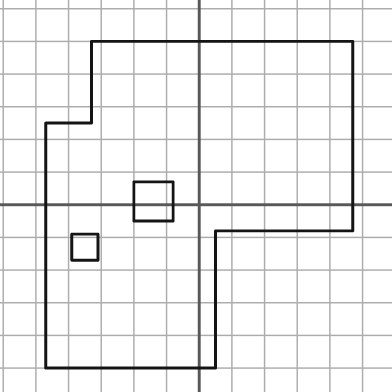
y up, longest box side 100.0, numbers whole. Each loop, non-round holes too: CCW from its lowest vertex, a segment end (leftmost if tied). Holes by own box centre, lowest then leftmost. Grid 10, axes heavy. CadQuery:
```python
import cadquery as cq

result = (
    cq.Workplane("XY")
    .moveTo(-47.0, -50.0)
    .lineTo(5.0, -50.0)
    .lineTo(5.0, -8.0)
    .lineTo(47.0, -8.0)
    .lineTo(47.0, 50.0)
    .lineTo(-33.0, 50.0)
    .lineTo(-33.0, 25.0)
    .lineTo(-47.0, 25.0)
    .close()
    .moveTo(-39.0, -17.0)
    .lineTo(-31.0, -17.0)
    .lineTo(-31.0, -9.0)
    .lineTo(-39.0, -9.0)
    .close()
    .moveTo(-20.0, -5.0)
    .lineTo(-8.0, -5.0)
    .lineTo(-8.0, 7.0)
    .lineTo(-20.0, 7.0)
    .close()
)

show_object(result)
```